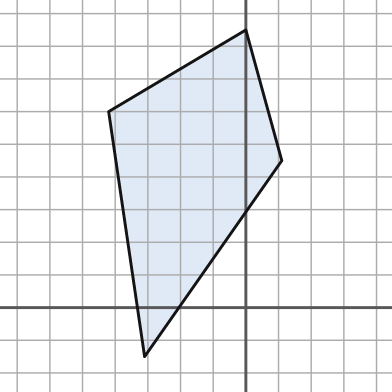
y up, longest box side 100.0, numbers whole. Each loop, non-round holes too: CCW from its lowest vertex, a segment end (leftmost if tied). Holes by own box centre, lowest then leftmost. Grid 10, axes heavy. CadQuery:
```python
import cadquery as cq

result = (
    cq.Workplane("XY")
    .moveTo(-31.0, -15.0)
    .lineTo(11.0, 45.0)
    .lineTo(0.0, 85.0)
    .lineTo(-42.0, 60.0)
    .close()
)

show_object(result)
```